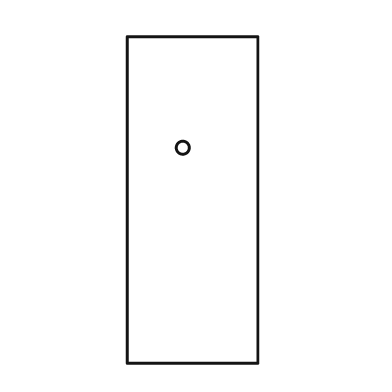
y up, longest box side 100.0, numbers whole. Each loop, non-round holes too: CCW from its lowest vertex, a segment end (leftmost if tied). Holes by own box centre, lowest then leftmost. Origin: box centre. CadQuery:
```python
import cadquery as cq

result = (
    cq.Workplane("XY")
    .moveTo(-20.0, -50.0)
    .lineTo(20.0, -50.0)
    .lineTo(20.0, 50.0)
    .lineTo(-20.0, 50.0)
    .close()
    .moveTo(-3.0, 16.0)
    .circle(2.0)
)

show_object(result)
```